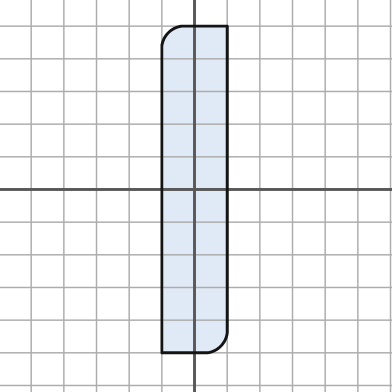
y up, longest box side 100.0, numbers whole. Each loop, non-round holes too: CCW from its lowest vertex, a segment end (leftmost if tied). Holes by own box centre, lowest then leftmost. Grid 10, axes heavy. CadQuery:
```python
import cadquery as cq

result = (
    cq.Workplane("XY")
    .moveTo(-10.0, -50.0)
    .lineTo(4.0, -50.0)
    .threePointArc((8.0, -48.0), (10.0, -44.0))
    .lineTo(10.0, 50.0)
    .lineTo(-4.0, 50.0)
    .threePointArc((-8.0, 48.0), (-10.0, 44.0))
    .close()
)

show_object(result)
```